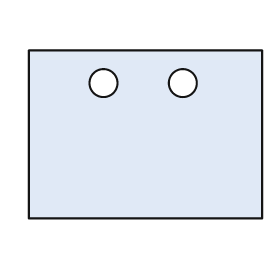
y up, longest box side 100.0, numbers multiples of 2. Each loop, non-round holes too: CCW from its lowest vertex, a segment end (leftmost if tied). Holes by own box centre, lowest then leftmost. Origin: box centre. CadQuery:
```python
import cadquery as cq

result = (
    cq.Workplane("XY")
    .moveTo(-50.0, -36.0)
    .lineTo(50.0, -36.0)
    .lineTo(50.0, 36.0)
    .lineTo(-50.0, 36.0)
    .close()
    .moveTo(-18.0, 22.0)
    .circle(6.0)
    .moveTo(16.0, 22.0)
    .circle(6.0)
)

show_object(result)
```